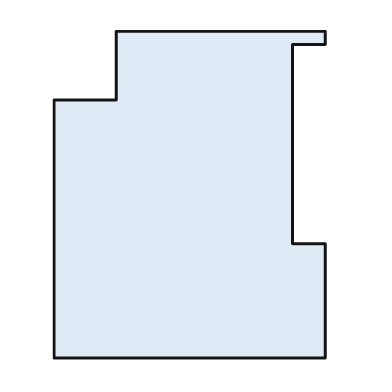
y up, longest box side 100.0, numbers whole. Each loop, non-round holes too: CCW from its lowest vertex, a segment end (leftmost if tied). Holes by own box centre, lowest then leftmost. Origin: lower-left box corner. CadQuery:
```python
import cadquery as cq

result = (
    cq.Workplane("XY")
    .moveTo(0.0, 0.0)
    .lineTo(83.0, 0.0)
    .lineTo(83.0, 35.0)
    .lineTo(73.0, 35.0)
    .lineTo(73.0, 96.0)
    .lineTo(83.0, 96.0)
    .lineTo(83.0, 100.0)
    .lineTo(19.0, 100.0)
    .lineTo(19.0, 79.0)
    .lineTo(0.0, 79.0)
    .close()
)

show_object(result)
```